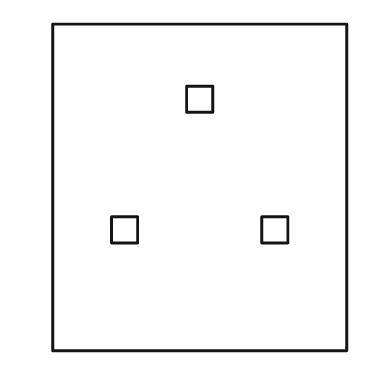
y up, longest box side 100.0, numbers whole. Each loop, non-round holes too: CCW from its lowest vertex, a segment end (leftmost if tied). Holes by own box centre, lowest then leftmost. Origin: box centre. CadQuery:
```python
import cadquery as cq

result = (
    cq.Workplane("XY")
    .moveTo(-45.0, -50.0)
    .lineTo(45.0, -50.0)
    .lineTo(45.0, 50.0)
    .lineTo(-45.0, 50.0)
    .close()
    .moveTo(-27.0, -17.0)
    .lineTo(-19.0, -17.0)
    .lineTo(-19.0, -9.0)
    .lineTo(-27.0, -9.0)
    .close()
    .moveTo(19.0, -17.0)
    .lineTo(27.0, -17.0)
    .lineTo(27.0, -9.0)
    .lineTo(19.0, -9.0)
    .close()
    .moveTo(-4.0, 23.0)
    .lineTo(4.0, 23.0)
    .lineTo(4.0, 31.0)
    .lineTo(-4.0, 31.0)
    .close()
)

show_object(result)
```